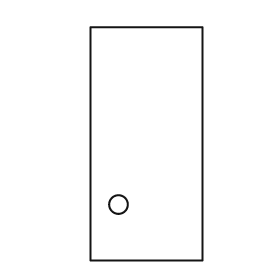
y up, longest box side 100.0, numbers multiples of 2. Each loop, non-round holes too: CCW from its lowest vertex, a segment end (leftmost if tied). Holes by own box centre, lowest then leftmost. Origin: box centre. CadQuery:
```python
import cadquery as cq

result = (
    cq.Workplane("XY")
    .moveTo(-24.0, -50.0)
    .lineTo(24.0, -50.0)
    .lineTo(24.0, 50.0)
    .lineTo(-24.0, 50.0)
    .close()
    .moveTo(-12.0, -26.0)
    .circle(4.0)
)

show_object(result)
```